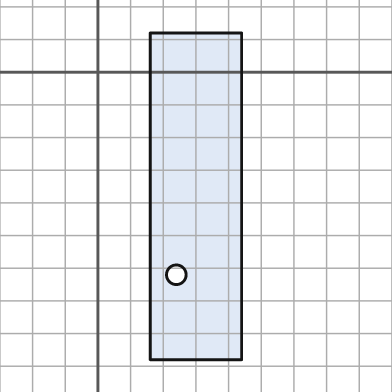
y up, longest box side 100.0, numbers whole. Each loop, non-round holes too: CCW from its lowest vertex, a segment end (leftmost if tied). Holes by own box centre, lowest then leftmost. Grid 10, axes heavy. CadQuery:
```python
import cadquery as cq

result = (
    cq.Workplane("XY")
    .moveTo(16.0, -88.0)
    .lineTo(44.0, -88.0)
    .lineTo(44.0, 12.0)
    .lineTo(16.0, 12.0)
    .close()
    .moveTo(24.0, -62.0)
    .circle(3.0)
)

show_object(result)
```